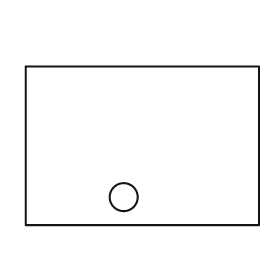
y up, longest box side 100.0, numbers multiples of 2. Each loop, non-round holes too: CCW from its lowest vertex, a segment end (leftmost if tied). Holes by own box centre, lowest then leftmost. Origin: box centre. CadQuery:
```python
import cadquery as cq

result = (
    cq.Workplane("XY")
    .moveTo(-50.0, -34.0)
    .lineTo(50.0, -34.0)
    .lineTo(50.0, 34.0)
    .lineTo(-50.0, 34.0)
    .close()
    .moveTo(-8.0, -22.0)
    .circle(6.0)
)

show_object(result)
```